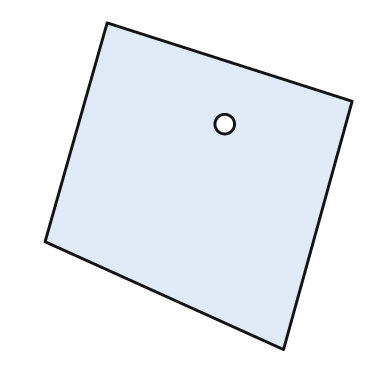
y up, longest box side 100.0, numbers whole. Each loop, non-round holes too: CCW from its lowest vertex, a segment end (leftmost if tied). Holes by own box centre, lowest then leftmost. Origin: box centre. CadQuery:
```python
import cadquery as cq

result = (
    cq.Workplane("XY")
    .moveTo(26.0, -50.0)
    .lineTo(47.0, 26.0)
    .lineTo(-28.0, 50.0)
    .lineTo(-47.0, -17.0)
    .close()
    .moveTo(8.0, 19.0)
    .circle(3.0)
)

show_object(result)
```